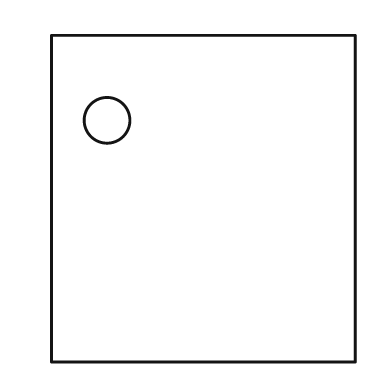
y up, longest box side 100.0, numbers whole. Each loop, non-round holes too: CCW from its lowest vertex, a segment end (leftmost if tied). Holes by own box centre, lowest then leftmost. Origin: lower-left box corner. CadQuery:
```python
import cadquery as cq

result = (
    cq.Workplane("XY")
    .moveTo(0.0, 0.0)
    .lineTo(93.0, 0.0)
    .lineTo(93.0, 100.0)
    .lineTo(0.0, 100.0)
    .close()
    .moveTo(17.0, 74.0)
    .circle(7.0)
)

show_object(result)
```